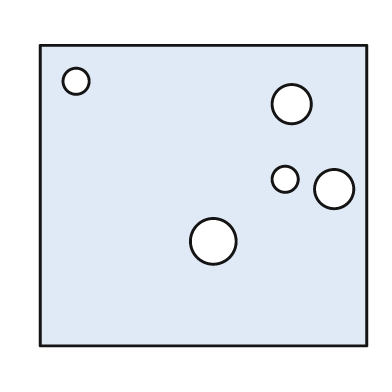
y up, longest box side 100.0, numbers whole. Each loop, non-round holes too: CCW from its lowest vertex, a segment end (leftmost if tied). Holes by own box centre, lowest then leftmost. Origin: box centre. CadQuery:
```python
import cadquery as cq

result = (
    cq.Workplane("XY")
    .moveTo(-50.0, -46.0)
    .lineTo(50.0, -46.0)
    .lineTo(50.0, 46.0)
    .lineTo(-50.0, 46.0)
    .close()
    .moveTo(3.0, -14.0)
    .circle(7.0)
    .moveTo(40.0, 2.0)
    .circle(6.0)
    .moveTo(25.0, 5.0)
    .circle(4.0)
    .moveTo(27.0, 28.0)
    .circle(6.0)
    .moveTo(-39.0, 35.0)
    .circle(4.0)
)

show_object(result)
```